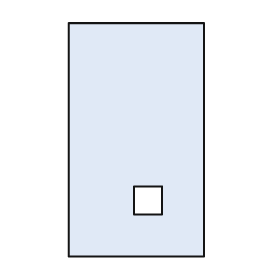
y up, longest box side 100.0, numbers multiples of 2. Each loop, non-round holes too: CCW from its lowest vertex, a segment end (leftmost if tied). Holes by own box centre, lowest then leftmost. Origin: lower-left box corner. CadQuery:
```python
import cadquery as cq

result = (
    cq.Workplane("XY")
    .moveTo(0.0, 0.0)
    .lineTo(58.0, 0.0)
    .lineTo(58.0, 100.0)
    .lineTo(0.0, 100.0)
    .close()
    .moveTo(28.0, 18.0)
    .lineTo(40.0, 18.0)
    .lineTo(40.0, 30.0)
    .lineTo(28.0, 30.0)
    .close()
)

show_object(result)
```